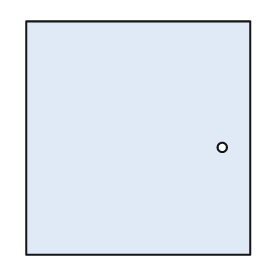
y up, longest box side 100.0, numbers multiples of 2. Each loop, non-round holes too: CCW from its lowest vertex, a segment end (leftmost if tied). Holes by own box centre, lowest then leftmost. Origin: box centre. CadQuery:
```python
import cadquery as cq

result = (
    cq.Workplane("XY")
    .moveTo(-48.0, -50.0)
    .lineTo(48.0, -50.0)
    .lineTo(48.0, 50.0)
    .lineTo(-48.0, 50.0)
    .close()
    .moveTo(36.0, -4.0)
    .circle(2.0)
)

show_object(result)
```